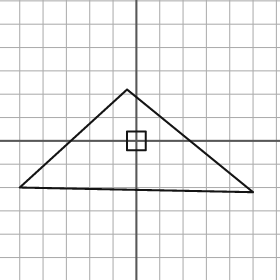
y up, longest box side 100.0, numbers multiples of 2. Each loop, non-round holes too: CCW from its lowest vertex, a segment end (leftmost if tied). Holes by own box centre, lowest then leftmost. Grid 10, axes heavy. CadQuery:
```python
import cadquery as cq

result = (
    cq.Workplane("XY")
    .moveTo(50.0, -22.0)
    .lineTo(-4.0, 22.0)
    .lineTo(-50.0, -20.0)
    .close()
    .moveTo(-4.0, -4.0)
    .lineTo(4.0, -4.0)
    .lineTo(4.0, 4.0)
    .lineTo(-4.0, 4.0)
    .close()
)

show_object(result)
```